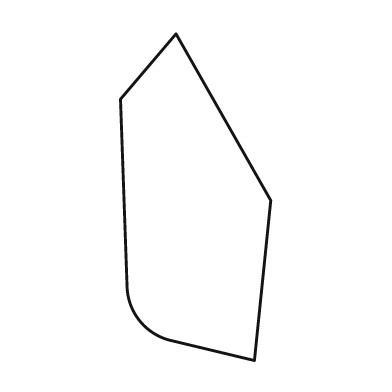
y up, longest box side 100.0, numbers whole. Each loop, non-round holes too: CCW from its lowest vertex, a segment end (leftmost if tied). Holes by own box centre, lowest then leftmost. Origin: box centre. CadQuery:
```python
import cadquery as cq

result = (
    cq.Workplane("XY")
    .moveTo(18.0, -50.0)
    .lineTo(23.0, -1.0)
    .lineTo(-6.0, 50.0)
    .lineTo(-23.0, 30.0)
    .lineTo(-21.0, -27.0)
    .threePointArc((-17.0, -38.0), (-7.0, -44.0))
    .close()
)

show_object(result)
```